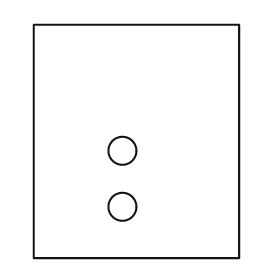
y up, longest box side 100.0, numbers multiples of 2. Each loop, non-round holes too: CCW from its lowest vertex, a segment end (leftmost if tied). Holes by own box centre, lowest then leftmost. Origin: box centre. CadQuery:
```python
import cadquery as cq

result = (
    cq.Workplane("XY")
    .moveTo(-44.0, -50.0)
    .lineTo(44.0, -50.0)
    .lineTo(44.0, 50.0)
    .lineTo(-44.0, 50.0)
    .close()
    .moveTo(-6.0, -28.0)
    .circle(6.0)
    .moveTo(-6.0, -4.0)
    .circle(6.0)
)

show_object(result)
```